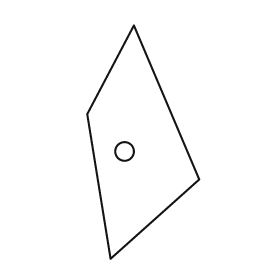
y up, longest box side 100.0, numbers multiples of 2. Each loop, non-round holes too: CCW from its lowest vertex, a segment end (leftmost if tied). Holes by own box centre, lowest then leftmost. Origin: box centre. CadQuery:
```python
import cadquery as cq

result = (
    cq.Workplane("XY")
    .moveTo(-14.0, -50.0)
    .lineTo(24.0, -16.0)
    .lineTo(-4.0, 50.0)
    .lineTo(-24.0, 12.0)
    .close()
    .moveTo(-8.0, -4.0)
    .circle(4.0)
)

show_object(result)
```